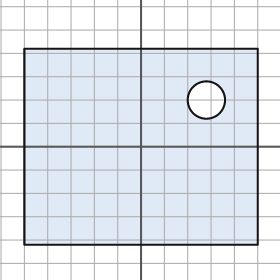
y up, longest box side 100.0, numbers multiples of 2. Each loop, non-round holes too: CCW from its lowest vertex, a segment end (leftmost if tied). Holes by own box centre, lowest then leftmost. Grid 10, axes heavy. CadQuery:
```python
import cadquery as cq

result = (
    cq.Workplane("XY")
    .moveTo(-50.0, -42.0)
    .lineTo(50.0, -42.0)
    .lineTo(50.0, 42.0)
    .lineTo(-50.0, 42.0)
    .close()
    .moveTo(28.0, 20.0)
    .circle(8.0)
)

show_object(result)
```